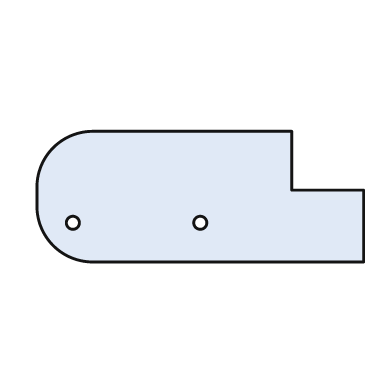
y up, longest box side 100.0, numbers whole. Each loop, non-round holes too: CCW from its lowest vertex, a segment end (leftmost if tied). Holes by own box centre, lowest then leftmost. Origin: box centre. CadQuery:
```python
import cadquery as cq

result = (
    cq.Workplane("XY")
    .moveTo(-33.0, -20.0)
    .lineTo(50.0, -20.0)
    .lineTo(50.0, 2.0)
    .lineTo(28.0, 2.0)
    .lineTo(28.0, 20.0)
    .lineTo(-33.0, 20.0)
    .threePointArc((-45.0, 15.0), (-50.0, 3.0))
    .lineTo(-50.0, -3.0)
    .threePointArc((-45.0, -15.0), (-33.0, -20.0))
    .close()
    .moveTo(-39.0, -8.0)
    .circle(2.0)
    .moveTo(0.0, -8.0)
    .circle(2.0)
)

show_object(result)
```